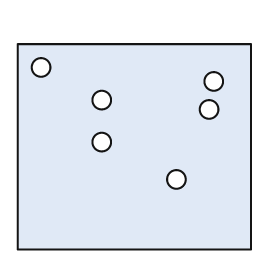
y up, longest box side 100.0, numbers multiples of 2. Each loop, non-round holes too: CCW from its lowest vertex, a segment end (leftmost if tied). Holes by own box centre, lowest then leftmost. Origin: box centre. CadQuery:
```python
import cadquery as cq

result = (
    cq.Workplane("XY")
    .moveTo(-50.0, -44.0)
    .lineTo(50.0, -44.0)
    .lineTo(50.0, 44.0)
    .lineTo(-50.0, 44.0)
    .close()
    .moveTo(18.0, -14.0)
    .circle(4.0)
    .moveTo(-14.0, 2.0)
    .circle(4.0)
    .moveTo(32.0, 16.0)
    .circle(4.0)
    .moveTo(-14.0, 20.0)
    .circle(4.0)
    .moveTo(34.0, 28.0)
    .circle(4.0)
    .moveTo(-40.0, 34.0)
    .circle(4.0)
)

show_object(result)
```